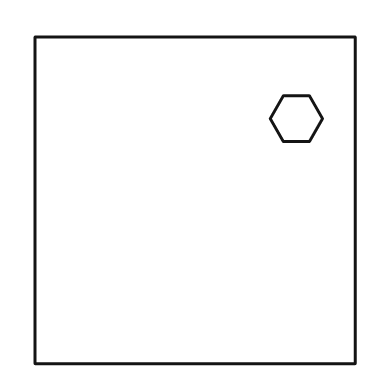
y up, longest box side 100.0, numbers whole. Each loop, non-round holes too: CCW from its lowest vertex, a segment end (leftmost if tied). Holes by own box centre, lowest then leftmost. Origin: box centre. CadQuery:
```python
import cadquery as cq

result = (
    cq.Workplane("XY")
    .moveTo(-49.0, -50.0)
    .lineTo(49.0, -50.0)
    .lineTo(49.0, 50.0)
    .lineTo(-49.0, 50.0)
    .close()
    .moveTo(27.0, 18.0)
    .lineTo(35.0, 18.0)
    .lineTo(39.0, 25.0)
    .lineTo(35.0, 32.0)
    .lineTo(27.0, 32.0)
    .lineTo(23.0, 25.0)
    .close()
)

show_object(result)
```